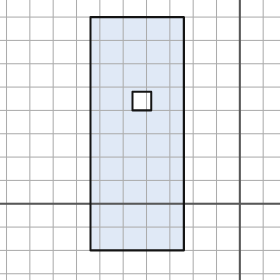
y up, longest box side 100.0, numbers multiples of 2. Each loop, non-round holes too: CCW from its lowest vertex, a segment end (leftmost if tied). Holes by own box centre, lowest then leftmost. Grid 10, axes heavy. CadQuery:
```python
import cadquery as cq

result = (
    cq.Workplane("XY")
    .moveTo(-64.0, -20.0)
    .lineTo(-24.0, -20.0)
    .lineTo(-24.0, 80.0)
    .lineTo(-64.0, 80.0)
    .close()
    .moveTo(-46.0, 40.0)
    .lineTo(-38.0, 40.0)
    .lineTo(-38.0, 48.0)
    .lineTo(-46.0, 48.0)
    .close()
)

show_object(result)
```